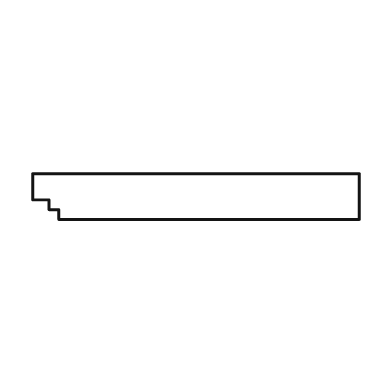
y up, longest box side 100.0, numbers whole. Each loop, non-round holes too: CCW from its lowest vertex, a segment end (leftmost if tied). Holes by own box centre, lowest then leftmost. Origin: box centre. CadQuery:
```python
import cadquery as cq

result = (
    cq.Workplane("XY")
    .moveTo(-42.0, -7.0)
    .lineTo(50.0, -7.0)
    .lineTo(50.0, 7.0)
    .lineTo(-50.0, 7.0)
    .lineTo(-50.0, -1.0)
    .lineTo(-45.0, -1.0)
    .lineTo(-45.0, -4.0)
    .lineTo(-42.0, -4.0)
    .close()
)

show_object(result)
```